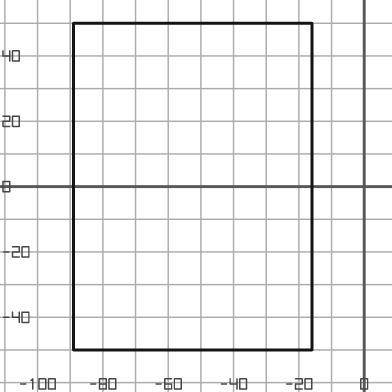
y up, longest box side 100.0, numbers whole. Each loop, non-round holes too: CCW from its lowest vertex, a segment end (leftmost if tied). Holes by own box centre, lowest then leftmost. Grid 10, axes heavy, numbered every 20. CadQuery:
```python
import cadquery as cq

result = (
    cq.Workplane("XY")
    .moveTo(-89.0, -50.0)
    .lineTo(-16.0, -50.0)
    .lineTo(-16.0, 50.0)
    .lineTo(-89.0, 50.0)
    .close()
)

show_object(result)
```